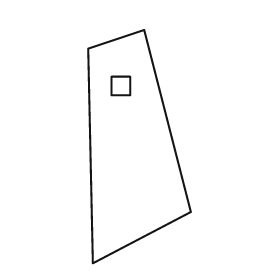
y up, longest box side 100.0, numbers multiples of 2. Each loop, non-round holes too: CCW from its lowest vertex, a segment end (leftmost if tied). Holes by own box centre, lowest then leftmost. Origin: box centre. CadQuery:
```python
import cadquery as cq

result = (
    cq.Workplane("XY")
    .moveTo(-20.0, -50.0)
    .lineTo(22.0, -28.0)
    .lineTo(2.0, 50.0)
    .lineTo(-22.0, 42.0)
    .close()
    .moveTo(-12.0, 22.0)
    .lineTo(-4.0, 22.0)
    .lineTo(-4.0, 30.0)
    .lineTo(-12.0, 30.0)
    .close()
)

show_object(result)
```